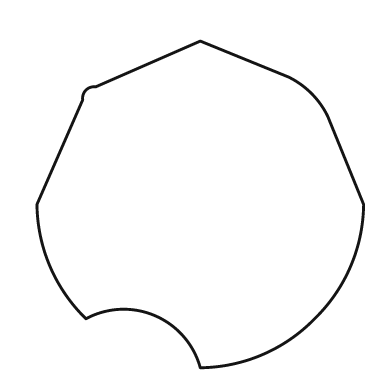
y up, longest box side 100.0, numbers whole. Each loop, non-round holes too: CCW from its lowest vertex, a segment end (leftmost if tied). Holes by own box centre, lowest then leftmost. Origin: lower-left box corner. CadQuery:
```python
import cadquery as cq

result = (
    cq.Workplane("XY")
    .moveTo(50.0, 0.0)
    .threePointArc((69.0, 4.0), (85.0, 15.0))
    .threePointArc((96.0, 31.0), (100.0, 50.0))
    .lineTo(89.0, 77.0)
    .threePointArc((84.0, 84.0), (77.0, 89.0))
    .lineTo(50.0, 100.0)
    .lineTo(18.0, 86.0)
    .threePointArc((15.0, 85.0), (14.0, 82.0))
    .lineTo(0.0, 50.0)
    .threePointArc((4.0, 31.0), (15.0, 15.0))
    .threePointArc((36.0, 16.0), (50.0, 0.0))
    .close()
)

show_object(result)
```